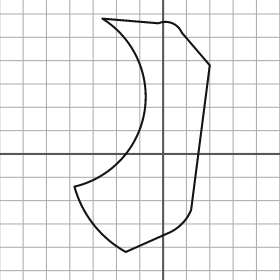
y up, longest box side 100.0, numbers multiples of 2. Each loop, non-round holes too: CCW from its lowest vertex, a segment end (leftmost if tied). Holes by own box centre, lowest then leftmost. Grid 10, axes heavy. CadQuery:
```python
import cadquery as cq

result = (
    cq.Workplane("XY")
    .moveTo(-16.0, -42.0)
    .lineTo(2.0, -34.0)
    .threePointArc((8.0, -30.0), (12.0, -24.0))
    .lineTo(20.0, 38.0)
    .lineTo(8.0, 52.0)
    .threePointArc((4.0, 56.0), (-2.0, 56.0))
    .lineTo(-26.0, 58.0)
    .threePointArc((-8.0, 18.0), (-38.0, -14.0))
    .threePointArc((-30.0, -30.0), (-16.0, -42.0))
    .close()
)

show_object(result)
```